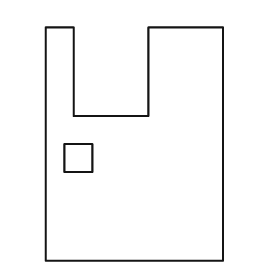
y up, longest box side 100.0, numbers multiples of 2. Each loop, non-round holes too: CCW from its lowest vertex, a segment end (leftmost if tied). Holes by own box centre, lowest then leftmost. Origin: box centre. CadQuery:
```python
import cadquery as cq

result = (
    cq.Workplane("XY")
    .moveTo(-38.0, -50.0)
    .lineTo(38.0, -50.0)
    .lineTo(38.0, 50.0)
    .lineTo(6.0, 50.0)
    .lineTo(6.0, 12.0)
    .lineTo(-26.0, 12.0)
    .lineTo(-26.0, 50.0)
    .lineTo(-38.0, 50.0)
    .close()
    .moveTo(-30.0, -12.0)
    .lineTo(-18.0, -12.0)
    .lineTo(-18.0, 0.0)
    .lineTo(-30.0, 0.0)
    .close()
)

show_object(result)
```